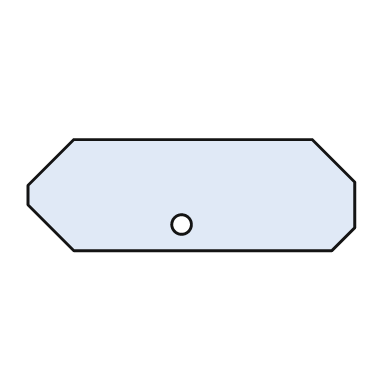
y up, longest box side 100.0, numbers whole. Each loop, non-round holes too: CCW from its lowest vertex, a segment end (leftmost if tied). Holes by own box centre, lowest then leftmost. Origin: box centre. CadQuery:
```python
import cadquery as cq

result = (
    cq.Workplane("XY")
    .moveTo(-36.0, -17.0)
    .lineTo(43.0, -17.0)
    .lineTo(50.0, -10.0)
    .lineTo(50.0, 4.0)
    .lineTo(37.0, 17.0)
    .lineTo(-36.0, 17.0)
    .lineTo(-50.0, 3.0)
    .lineTo(-50.0, -3.0)
    .close()
    .moveTo(-3.0, -9.0)
    .circle(3.0)
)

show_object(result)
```